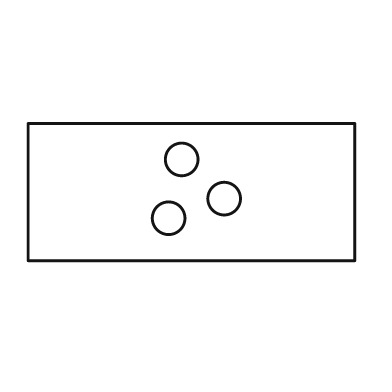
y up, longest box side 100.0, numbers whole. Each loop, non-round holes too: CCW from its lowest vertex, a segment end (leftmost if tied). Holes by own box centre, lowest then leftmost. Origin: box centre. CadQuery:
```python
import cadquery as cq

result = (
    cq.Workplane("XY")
    .moveTo(-50.0, -21.0)
    .lineTo(50.0, -21.0)
    .lineTo(50.0, 21.0)
    .lineTo(-50.0, 21.0)
    .close()
    .moveTo(-7.0, -8.0)
    .circle(5.0)
    .moveTo(10.0, -2.0)
    .circle(5.0)
    .moveTo(-3.0, 10.0)
    .circle(5.0)
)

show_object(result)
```